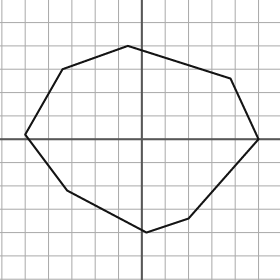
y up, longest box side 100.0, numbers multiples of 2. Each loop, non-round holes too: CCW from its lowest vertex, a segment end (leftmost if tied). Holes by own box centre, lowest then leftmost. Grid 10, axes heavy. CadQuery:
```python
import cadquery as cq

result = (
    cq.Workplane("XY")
    .moveTo(2.0, -40.0)
    .lineTo(20.0, -34.0)
    .lineTo(50.0, 0.0)
    .lineTo(38.0, 26.0)
    .lineTo(-6.0, 40.0)
    .lineTo(-34.0, 30.0)
    .lineTo(-50.0, 2.0)
    .lineTo(-32.0, -22.0)
    .close()
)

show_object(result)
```